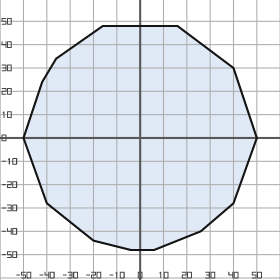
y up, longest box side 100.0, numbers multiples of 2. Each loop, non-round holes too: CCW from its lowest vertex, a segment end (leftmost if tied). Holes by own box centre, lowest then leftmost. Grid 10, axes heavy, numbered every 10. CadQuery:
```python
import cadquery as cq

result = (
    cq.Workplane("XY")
    .moveTo(-4.0, -48.0)
    .lineTo(6.0, -48.0)
    .lineTo(26.0, -40.0)
    .lineTo(40.0, -28.0)
    .lineTo(50.0, 0.0)
    .lineTo(40.0, 30.0)
    .lineTo(16.0, 48.0)
    .lineTo(-16.0, 48.0)
    .lineTo(-36.0, 34.0)
    .lineTo(-42.0, 24.0)
    .lineTo(-50.0, 0.0)
    .lineTo(-40.0, -28.0)
    .lineTo(-20.0, -44.0)
    .close()
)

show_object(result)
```